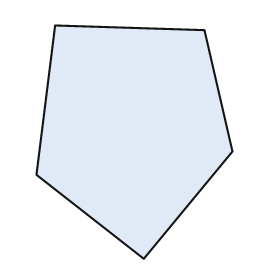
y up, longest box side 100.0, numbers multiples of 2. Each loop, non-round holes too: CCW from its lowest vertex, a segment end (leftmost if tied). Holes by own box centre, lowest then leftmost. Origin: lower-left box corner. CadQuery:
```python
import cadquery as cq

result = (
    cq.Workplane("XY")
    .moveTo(46.0, 0.0)
    .lineTo(84.0, 46.0)
    .lineTo(72.0, 98.0)
    .lineTo(8.0, 100.0)
    .lineTo(0.0, 36.0)
    .close()
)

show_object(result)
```